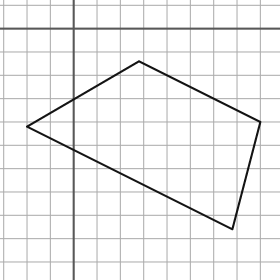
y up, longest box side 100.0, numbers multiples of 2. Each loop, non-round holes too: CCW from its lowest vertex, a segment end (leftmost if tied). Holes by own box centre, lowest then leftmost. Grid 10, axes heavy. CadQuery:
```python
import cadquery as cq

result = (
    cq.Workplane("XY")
    .moveTo(68.0, -86.0)
    .lineTo(80.0, -40.0)
    .lineTo(28.0, -14.0)
    .lineTo(-20.0, -42.0)
    .close()
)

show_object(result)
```